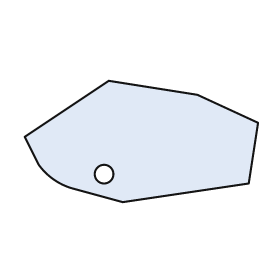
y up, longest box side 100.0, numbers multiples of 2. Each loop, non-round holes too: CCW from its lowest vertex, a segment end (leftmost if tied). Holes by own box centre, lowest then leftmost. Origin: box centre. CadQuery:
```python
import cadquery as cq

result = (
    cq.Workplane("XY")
    .moveTo(-8.0, -26.0)
    .lineTo(46.0, -18.0)
    .lineTo(50.0, 8.0)
    .lineTo(24.0, 20.0)
    .lineTo(-14.0, 26.0)
    .lineTo(-50.0, 2.0)
    .lineTo(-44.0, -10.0)
    .threePointArc((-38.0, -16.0), (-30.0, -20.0))
    .close()
    .moveTo(-16.0, -14.0)
    .circle(4.0)
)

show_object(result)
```